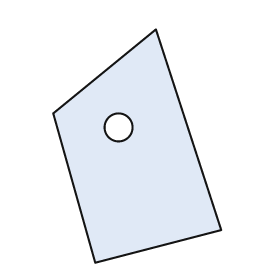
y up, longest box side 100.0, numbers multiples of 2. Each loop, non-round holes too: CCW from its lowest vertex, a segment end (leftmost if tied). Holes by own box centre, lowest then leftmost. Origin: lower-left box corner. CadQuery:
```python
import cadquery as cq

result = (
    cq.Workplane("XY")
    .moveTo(18.0, 0.0)
    .lineTo(72.0, 14.0)
    .lineTo(44.0, 100.0)
    .lineTo(0.0, 64.0)
    .close()
    .moveTo(28.0, 58.0)
    .circle(6.0)
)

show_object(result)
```